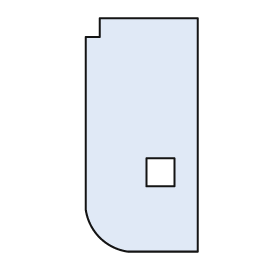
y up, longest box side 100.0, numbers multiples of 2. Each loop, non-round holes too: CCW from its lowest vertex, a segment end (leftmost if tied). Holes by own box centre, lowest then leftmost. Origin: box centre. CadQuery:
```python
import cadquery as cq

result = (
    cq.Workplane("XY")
    .moveTo(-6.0, -50.0)
    .lineTo(24.0, -50.0)
    .lineTo(24.0, 50.0)
    .lineTo(-18.0, 50.0)
    .lineTo(-18.0, 42.0)
    .lineTo(-24.0, 42.0)
    .lineTo(-24.0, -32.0)
    .threePointArc((-18.0, -44.0), (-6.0, -50.0))
    .close()
    .moveTo(2.0, -22.0)
    .lineTo(14.0, -22.0)
    .lineTo(14.0, -10.0)
    .lineTo(2.0, -10.0)
    .close()
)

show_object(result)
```